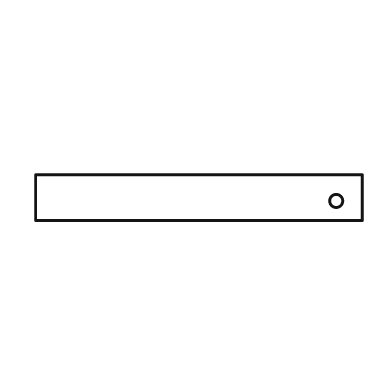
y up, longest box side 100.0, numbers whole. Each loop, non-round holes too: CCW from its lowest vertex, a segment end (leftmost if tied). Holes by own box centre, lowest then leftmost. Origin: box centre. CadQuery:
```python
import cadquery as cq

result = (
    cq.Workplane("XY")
    .moveTo(-50.0, -7.0)
    .lineTo(50.0, -7.0)
    .lineTo(50.0, 7.0)
    .lineTo(-50.0, 7.0)
    .close()
    .moveTo(42.0, -1.0)
    .circle(2.0)
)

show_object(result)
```